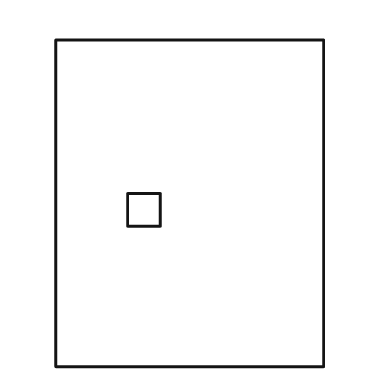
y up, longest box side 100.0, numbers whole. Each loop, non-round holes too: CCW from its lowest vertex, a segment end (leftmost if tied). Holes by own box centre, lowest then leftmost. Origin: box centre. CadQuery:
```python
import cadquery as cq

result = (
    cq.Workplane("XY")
    .moveTo(-41.0, -50.0)
    .lineTo(41.0, -50.0)
    .lineTo(41.0, 50.0)
    .lineTo(-41.0, 50.0)
    .close()
    .moveTo(-19.0, -7.0)
    .lineTo(-9.0, -7.0)
    .lineTo(-9.0, 3.0)
    .lineTo(-19.0, 3.0)
    .close()
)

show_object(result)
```